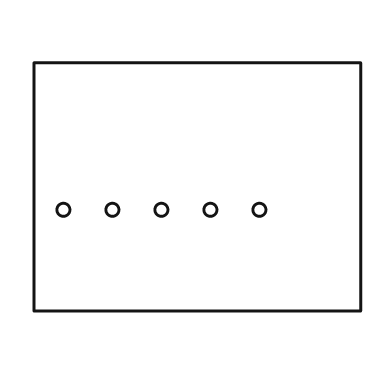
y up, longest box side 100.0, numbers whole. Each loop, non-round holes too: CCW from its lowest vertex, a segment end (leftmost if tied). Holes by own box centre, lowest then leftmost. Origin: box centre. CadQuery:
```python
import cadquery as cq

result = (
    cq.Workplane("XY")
    .moveTo(-50.0, -38.0)
    .lineTo(50.0, -38.0)
    .lineTo(50.0, 38.0)
    .lineTo(-50.0, 38.0)
    .close()
    .moveTo(-41.0, -7.0)
    .circle(2.0)
    .moveTo(-26.0, -7.0)
    .circle(2.0)
    .moveTo(-11.0, -7.0)
    .circle(2.0)
    .moveTo(4.0, -7.0)
    .circle(2.0)
    .moveTo(19.0, -7.0)
    .circle(2.0)
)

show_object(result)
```